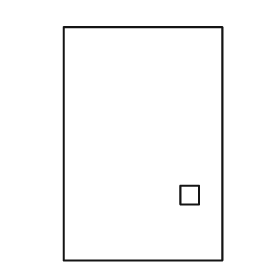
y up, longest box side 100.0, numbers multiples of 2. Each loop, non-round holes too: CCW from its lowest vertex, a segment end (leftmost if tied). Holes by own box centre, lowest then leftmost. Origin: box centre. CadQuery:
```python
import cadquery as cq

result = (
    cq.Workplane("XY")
    .moveTo(-34.0, -50.0)
    .lineTo(34.0, -50.0)
    .lineTo(34.0, 50.0)
    .lineTo(-34.0, 50.0)
    .close()
    .moveTo(16.0, -26.0)
    .lineTo(24.0, -26.0)
    .lineTo(24.0, -18.0)
    .lineTo(16.0, -18.0)
    .close()
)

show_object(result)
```